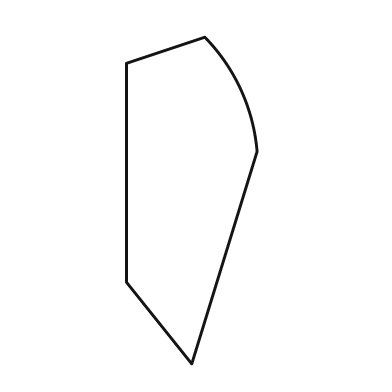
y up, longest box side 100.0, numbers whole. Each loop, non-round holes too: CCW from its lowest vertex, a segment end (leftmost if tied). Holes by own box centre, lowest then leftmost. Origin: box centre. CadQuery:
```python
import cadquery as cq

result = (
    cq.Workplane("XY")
    .moveTo(0.0, -50.0)
    .lineTo(20.0, 15.0)
    .threePointArc((15.0, 34.0), (4.0, 50.0))
    .lineTo(-20.0, 42.0)
    .lineTo(-20.0, -25.0)
    .close()
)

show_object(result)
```